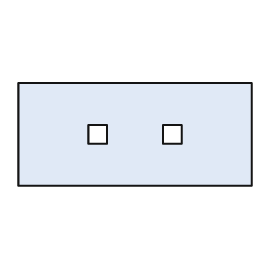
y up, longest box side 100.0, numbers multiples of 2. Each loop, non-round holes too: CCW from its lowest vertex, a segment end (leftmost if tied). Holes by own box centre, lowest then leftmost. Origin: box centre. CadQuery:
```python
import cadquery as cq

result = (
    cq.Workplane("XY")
    .moveTo(-50.0, -22.0)
    .lineTo(50.0, -22.0)
    .lineTo(50.0, 22.0)
    .lineTo(-50.0, 22.0)
    .close()
    .moveTo(-20.0, -4.0)
    .lineTo(-12.0, -4.0)
    .lineTo(-12.0, 4.0)
    .lineTo(-20.0, 4.0)
    .close()
    .moveTo(12.0, -4.0)
    .lineTo(20.0, -4.0)
    .lineTo(20.0, 4.0)
    .lineTo(12.0, 4.0)
    .close()
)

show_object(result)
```